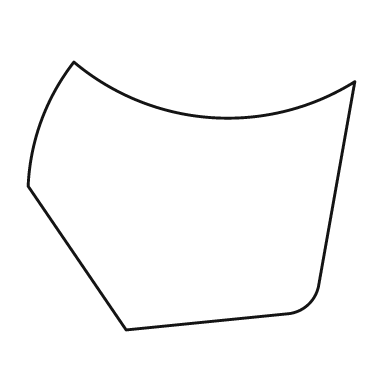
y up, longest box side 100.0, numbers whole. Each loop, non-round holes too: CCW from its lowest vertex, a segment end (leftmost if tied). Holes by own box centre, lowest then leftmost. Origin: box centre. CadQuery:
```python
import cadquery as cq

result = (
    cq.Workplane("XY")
    .moveTo(-20.0, -41.0)
    .lineTo(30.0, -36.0)
    .threePointArc((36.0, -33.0), (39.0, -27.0))
    .lineTo(50.0, 35.0)
    .threePointArc((6.0, 24.0), (-36.0, 41.0))
    .threePointArc((-46.0, 23.0), (-50.0, 3.0))
    .close()
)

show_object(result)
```